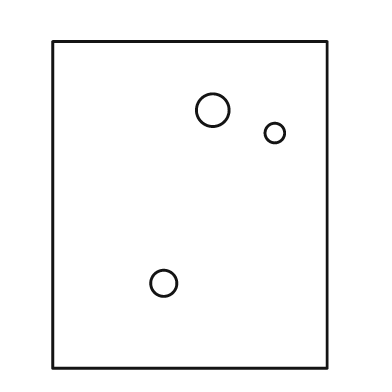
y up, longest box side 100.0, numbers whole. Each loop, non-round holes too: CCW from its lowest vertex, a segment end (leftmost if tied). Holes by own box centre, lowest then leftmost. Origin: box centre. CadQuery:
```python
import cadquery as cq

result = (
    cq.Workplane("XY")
    .moveTo(-42.0, -50.0)
    .lineTo(42.0, -50.0)
    .lineTo(42.0, 50.0)
    .lineTo(-42.0, 50.0)
    .close()
    .moveTo(-8.0, -24.0)
    .circle(4.0)
    .moveTo(26.0, 22.0)
    .circle(3.0)
    .moveTo(7.0, 29.0)
    .circle(5.0)
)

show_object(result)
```